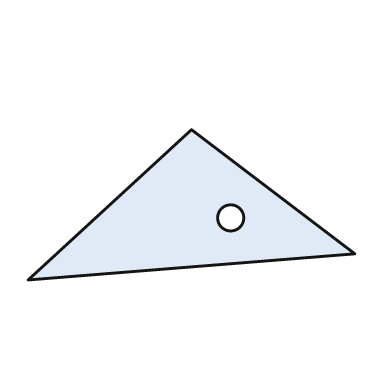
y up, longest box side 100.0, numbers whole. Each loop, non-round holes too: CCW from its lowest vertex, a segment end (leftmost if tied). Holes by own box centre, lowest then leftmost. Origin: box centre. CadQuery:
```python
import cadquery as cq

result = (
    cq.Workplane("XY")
    .moveTo(-50.0, -23.0)
    .lineTo(50.0, -15.0)
    .lineTo(0.0, 23.0)
    .close()
    .moveTo(12.0, -4.0)
    .circle(4.0)
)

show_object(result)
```